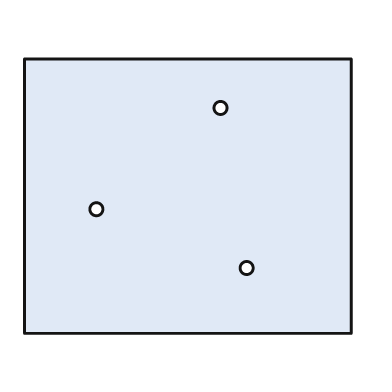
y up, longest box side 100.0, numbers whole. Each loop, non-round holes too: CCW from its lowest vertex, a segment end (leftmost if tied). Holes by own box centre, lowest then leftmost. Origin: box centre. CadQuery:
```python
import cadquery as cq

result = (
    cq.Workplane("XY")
    .moveTo(-50.0, -42.0)
    .lineTo(50.0, -42.0)
    .lineTo(50.0, 42.0)
    .lineTo(-50.0, 42.0)
    .close()
    .moveTo(18.0, -22.0)
    .circle(2.0)
    .moveTo(-28.0, -4.0)
    .circle(2.0)
    .moveTo(10.0, 27.0)
    .circle(2.0)
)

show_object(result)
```